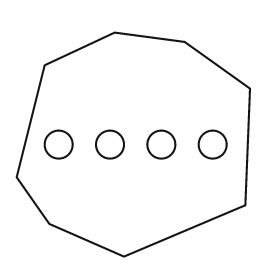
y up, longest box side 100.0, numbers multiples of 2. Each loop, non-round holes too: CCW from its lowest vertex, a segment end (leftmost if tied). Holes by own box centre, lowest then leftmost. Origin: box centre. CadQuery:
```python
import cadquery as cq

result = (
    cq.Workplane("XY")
    .moveTo(-4.0, -48.0)
    .lineTo(48.0, -26.0)
    .lineTo(50.0, 24.0)
    .lineTo(22.0, 44.0)
    .lineTo(-8.0, 48.0)
    .lineTo(-38.0, 34.0)
    .lineTo(-50.0, -14.0)
    .lineTo(-36.0, -34.0)
    .close()
    .moveTo(-32.0, 0.0)
    .circle(6.0)
    .moveTo(-10.0, 0.0)
    .circle(6.0)
    .moveTo(12.0, 0.0)
    .circle(6.0)
    .moveTo(34.0, 0.0)
    .circle(6.0)
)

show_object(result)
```